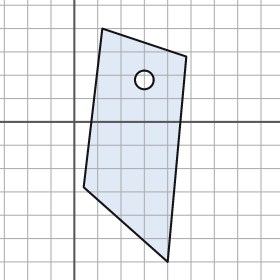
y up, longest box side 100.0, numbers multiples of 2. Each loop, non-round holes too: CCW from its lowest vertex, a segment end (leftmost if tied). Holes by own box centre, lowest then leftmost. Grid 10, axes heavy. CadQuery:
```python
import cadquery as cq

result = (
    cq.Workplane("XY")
    .moveTo(40.0, -60.0)
    .lineTo(48.0, 28.0)
    .lineTo(12.0, 40.0)
    .lineTo(4.0, -28.0)
    .close()
    .moveTo(30.0, 18.0)
    .circle(4.0)
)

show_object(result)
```